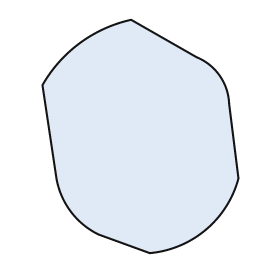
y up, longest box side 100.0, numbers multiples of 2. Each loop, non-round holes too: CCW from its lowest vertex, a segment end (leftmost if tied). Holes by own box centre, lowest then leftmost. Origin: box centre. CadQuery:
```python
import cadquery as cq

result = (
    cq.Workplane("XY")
    .moveTo(4.0, -50.0)
    .threePointArc((28.0, -40.0), (42.0, -18.0))
    .lineTo(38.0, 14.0)
    .threePointArc((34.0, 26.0), (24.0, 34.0))
    .lineTo(-4.0, 50.0)
    .threePointArc((-26.0, 40.0), (-42.0, 22.0))
    .lineTo(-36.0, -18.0)
    .threePointArc((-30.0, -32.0), (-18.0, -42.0))
    .close()
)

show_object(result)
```